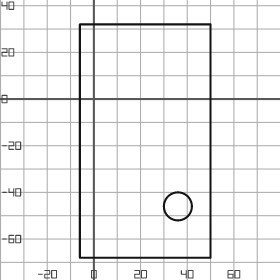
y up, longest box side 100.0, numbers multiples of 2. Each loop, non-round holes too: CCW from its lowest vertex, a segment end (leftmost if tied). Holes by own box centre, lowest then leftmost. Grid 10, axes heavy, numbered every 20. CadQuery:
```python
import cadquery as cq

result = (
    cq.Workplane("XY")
    .moveTo(-6.0, -68.0)
    .lineTo(50.0, -68.0)
    .lineTo(50.0, 32.0)
    .lineTo(-6.0, 32.0)
    .close()
    .moveTo(36.0, -46.0)
    .circle(6.0)
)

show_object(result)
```